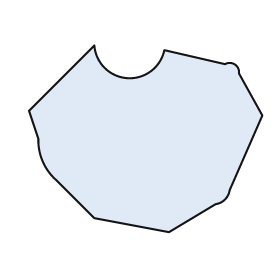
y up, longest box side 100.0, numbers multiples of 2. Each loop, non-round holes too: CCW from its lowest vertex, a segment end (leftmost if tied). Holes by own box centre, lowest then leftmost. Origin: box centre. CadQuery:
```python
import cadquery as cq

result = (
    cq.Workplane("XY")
    .moveTo(10.0, -40.0)
    .lineTo(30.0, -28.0)
    .threePointArc((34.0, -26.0), (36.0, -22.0))
    .lineTo(50.0, 10.0)
    .lineTo(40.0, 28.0)
    .threePointArc((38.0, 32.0), (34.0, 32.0))
    .lineTo(8.0, 38.0)
    .threePointArc((-8.0, 26.0), (-22.0, 40.0))
    .lineTo(-50.0, 12.0)
    .lineTo(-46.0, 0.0)
    .threePointArc((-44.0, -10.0), (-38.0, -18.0))
    .lineTo(-22.0, -34.0)
    .close()
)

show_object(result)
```